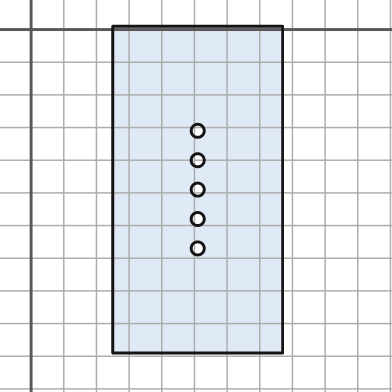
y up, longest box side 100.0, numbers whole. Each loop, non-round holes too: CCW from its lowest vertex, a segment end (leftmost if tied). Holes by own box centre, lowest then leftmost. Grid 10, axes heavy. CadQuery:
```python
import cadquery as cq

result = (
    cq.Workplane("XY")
    .moveTo(25.0, -99.0)
    .lineTo(77.0, -99.0)
    .lineTo(77.0, 1.0)
    .lineTo(25.0, 1.0)
    .close()
    .moveTo(51.0, -67.0)
    .circle(2.0)
    .moveTo(51.0, -58.0)
    .circle(2.0)
    .moveTo(51.0, -49.0)
    .circle(2.0)
    .moveTo(51.0, -40.0)
    .circle(2.0)
    .moveTo(51.0, -31.0)
    .circle(2.0)
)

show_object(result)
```